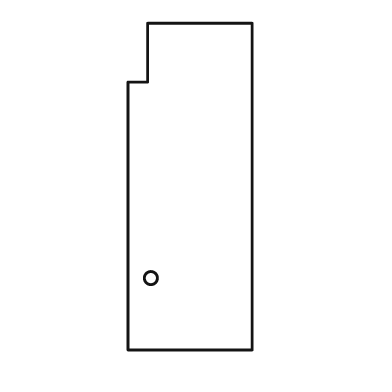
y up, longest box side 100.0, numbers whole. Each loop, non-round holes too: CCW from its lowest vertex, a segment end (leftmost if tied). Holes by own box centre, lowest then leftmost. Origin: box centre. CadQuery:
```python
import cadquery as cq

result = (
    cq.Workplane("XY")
    .moveTo(-19.0, -50.0)
    .lineTo(19.0, -50.0)
    .lineTo(19.0, 50.0)
    .lineTo(-13.0, 50.0)
    .lineTo(-13.0, 32.0)
    .lineTo(-19.0, 32.0)
    .close()
    .moveTo(-12.0, -28.0)
    .circle(2.0)
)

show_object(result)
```